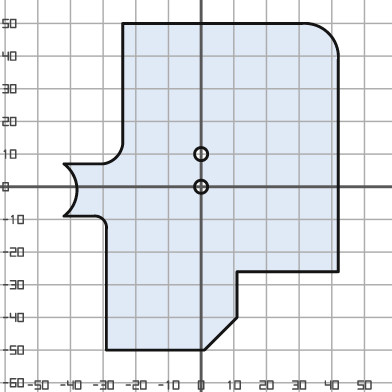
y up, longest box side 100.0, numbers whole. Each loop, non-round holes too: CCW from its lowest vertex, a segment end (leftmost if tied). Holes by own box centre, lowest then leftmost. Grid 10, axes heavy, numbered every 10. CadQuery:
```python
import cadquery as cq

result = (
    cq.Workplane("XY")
    .moveTo(-29.0, -50.0)
    .lineTo(1.0, -50.0)
    .lineTo(11.0, -40.0)
    .lineTo(11.0, -26.0)
    .lineTo(42.0, -26.0)
    .lineTo(42.0, 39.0)
    .threePointArc((39.0, 47.0), (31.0, 50.0))
    .lineTo(-24.0, 50.0)
    .lineTo(-24.0, 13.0)
    .threePointArc((-26.0, 9.0), (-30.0, 7.0))
    .lineTo(-42.0, 7.0)
    .threePointArc((-38.0, -1.0), (-42.0, -9.0))
    .lineTo(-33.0, -9.0)
    .threePointArc((-30.0, -10.0), (-29.0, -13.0))
    .close()
    .moveTo(0.0, 0.0)
    .circle(2.0)
    .moveTo(0.0, 10.0)
    .circle(2.0)
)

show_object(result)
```